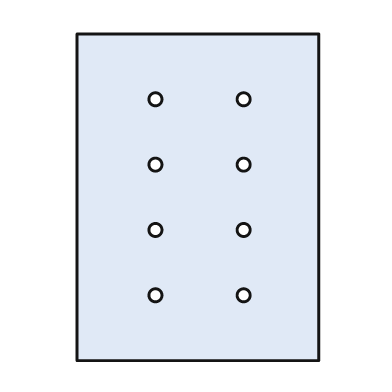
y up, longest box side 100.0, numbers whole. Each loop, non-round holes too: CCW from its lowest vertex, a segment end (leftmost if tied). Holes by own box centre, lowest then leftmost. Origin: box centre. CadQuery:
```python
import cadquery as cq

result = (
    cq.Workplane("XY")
    .moveTo(-37.0, -50.0)
    .lineTo(37.0, -50.0)
    .lineTo(37.0, 50.0)
    .lineTo(-37.0, 50.0)
    .close()
    .moveTo(-13.0, -30.0)
    .circle(2.0)
    .moveTo(14.0, -30.0)
    .circle(2.0)
    .moveTo(-13.0, -10.0)
    .circle(2.0)
    .moveTo(14.0, -10.0)
    .circle(2.0)
    .moveTo(-13.0, 10.0)
    .circle(2.0)
    .moveTo(14.0, 10.0)
    .circle(2.0)
    .moveTo(-13.0, 30.0)
    .circle(2.0)
    .moveTo(14.0, 30.0)
    .circle(2.0)
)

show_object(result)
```